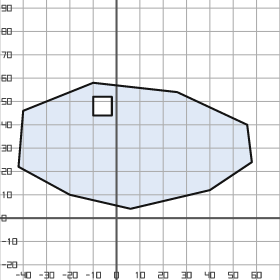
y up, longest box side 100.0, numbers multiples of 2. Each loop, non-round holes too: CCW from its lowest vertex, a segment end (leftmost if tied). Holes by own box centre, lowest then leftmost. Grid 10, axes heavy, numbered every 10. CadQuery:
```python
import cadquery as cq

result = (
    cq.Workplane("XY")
    .moveTo(6.0, 4.0)
    .lineTo(40.0, 12.0)
    .lineTo(58.0, 24.0)
    .lineTo(56.0, 40.0)
    .lineTo(26.0, 54.0)
    .lineTo(-10.0, 58.0)
    .lineTo(-40.0, 46.0)
    .lineTo(-42.0, 22.0)
    .lineTo(-20.0, 10.0)
    .close()
    .moveTo(-10.0, 44.0)
    .lineTo(-2.0, 44.0)
    .lineTo(-2.0, 52.0)
    .lineTo(-10.0, 52.0)
    .close()
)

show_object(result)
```